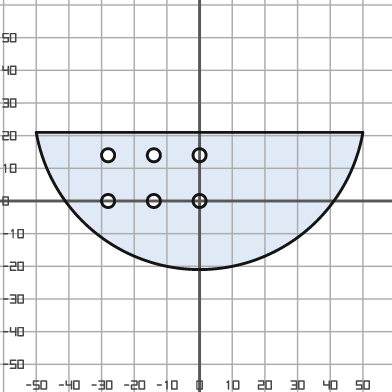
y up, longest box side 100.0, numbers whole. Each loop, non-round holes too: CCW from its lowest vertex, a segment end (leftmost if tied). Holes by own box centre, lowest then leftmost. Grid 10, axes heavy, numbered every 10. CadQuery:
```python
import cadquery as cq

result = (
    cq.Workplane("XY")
    .moveTo(-50.0, 21.0)
    .threePointArc((0.0, -21.0), (50.0, 21.0))
    .close()
    .moveTo(-28.0, 0.0)
    .circle(2.0)
    .moveTo(-14.0, 0.0)
    .circle(2.0)
    .moveTo(0.0, 0.0)
    .circle(2.0)
    .moveTo(-28.0, 14.0)
    .circle(2.0)
    .moveTo(-14.0, 14.0)
    .circle(2.0)
    .moveTo(0.0, 14.0)
    .circle(2.0)
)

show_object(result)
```